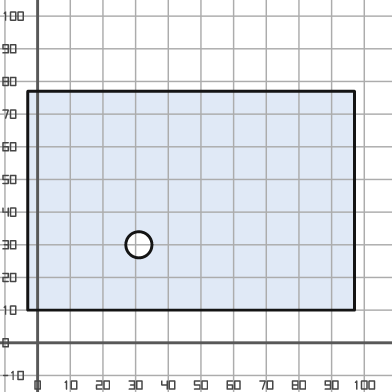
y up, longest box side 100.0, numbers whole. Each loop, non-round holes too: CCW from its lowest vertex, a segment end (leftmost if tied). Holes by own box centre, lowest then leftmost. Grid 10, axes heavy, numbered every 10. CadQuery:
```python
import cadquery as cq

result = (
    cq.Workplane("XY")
    .moveTo(-3.0, 10.0)
    .lineTo(97.0, 10.0)
    .lineTo(97.0, 77.0)
    .lineTo(-3.0, 77.0)
    .close()
    .moveTo(31.0, 30.0)
    .circle(4.0)
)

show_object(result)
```